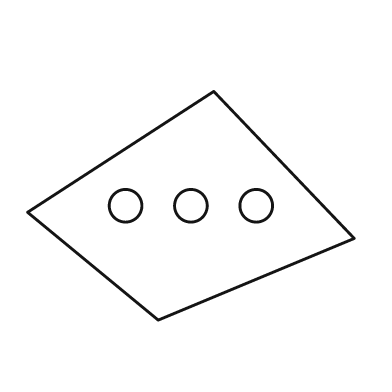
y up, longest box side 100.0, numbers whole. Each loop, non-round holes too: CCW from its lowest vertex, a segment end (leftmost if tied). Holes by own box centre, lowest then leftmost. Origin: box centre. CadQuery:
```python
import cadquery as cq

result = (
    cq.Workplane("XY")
    .moveTo(-10.0, -35.0)
    .lineTo(50.0, -10.0)
    .lineTo(7.0, 35.0)
    .lineTo(-50.0, -2.0)
    .close()
    .moveTo(-20.0, 0.0)
    .circle(5.0)
    .moveTo(0.0, 0.0)
    .circle(5.0)
    .moveTo(20.0, 0.0)
    .circle(5.0)
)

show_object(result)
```